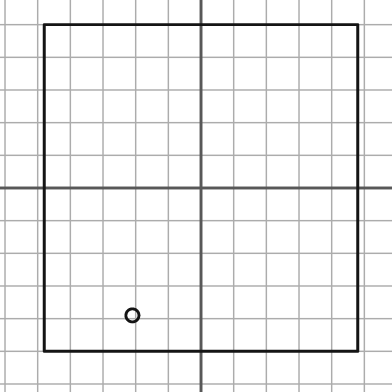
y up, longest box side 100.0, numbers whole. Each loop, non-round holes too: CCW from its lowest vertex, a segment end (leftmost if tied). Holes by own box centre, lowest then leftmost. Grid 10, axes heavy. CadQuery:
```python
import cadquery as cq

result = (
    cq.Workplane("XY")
    .moveTo(-48.0, -50.0)
    .lineTo(48.0, -50.0)
    .lineTo(48.0, 50.0)
    .lineTo(-48.0, 50.0)
    .close()
    .moveTo(-21.0, -39.0)
    .circle(2.0)
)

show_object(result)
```